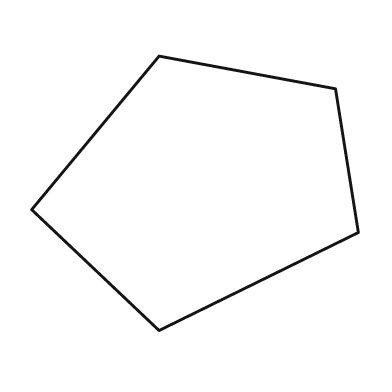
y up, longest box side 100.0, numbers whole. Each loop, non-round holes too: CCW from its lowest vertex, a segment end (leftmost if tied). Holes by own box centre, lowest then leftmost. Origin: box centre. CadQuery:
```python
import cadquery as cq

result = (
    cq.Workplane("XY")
    .moveTo(-11.0, -42.0)
    .lineTo(50.0, -12.0)
    .lineTo(43.0, 32.0)
    .lineTo(-11.0, 42.0)
    .lineTo(-50.0, -5.0)
    .close()
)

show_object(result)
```